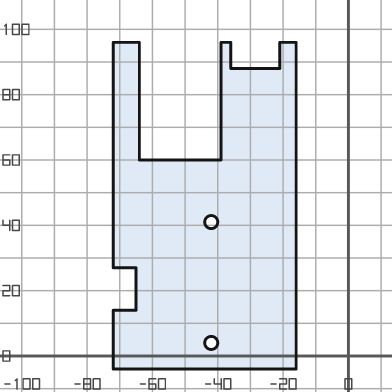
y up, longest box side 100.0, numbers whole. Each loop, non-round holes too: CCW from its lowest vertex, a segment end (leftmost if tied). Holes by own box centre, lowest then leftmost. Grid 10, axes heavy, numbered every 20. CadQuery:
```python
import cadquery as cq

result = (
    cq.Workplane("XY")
    .moveTo(-72.0, -4.0)
    .lineTo(-16.0, -4.0)
    .lineTo(-16.0, 96.0)
    .lineTo(-21.0, 96.0)
    .lineTo(-21.0, 88.0)
    .lineTo(-36.0, 88.0)
    .lineTo(-36.0, 96.0)
    .lineTo(-39.0, 96.0)
    .lineTo(-39.0, 60.0)
    .lineTo(-64.0, 60.0)
    .lineTo(-64.0, 96.0)
    .lineTo(-72.0, 96.0)
    .lineTo(-72.0, 27.0)
    .lineTo(-65.0, 27.0)
    .lineTo(-65.0, 14.0)
    .lineTo(-72.0, 14.0)
    .close()
    .moveTo(-42.0, 4.0)
    .circle(2.0)
    .moveTo(-42.0, 41.0)
    .circle(2.0)
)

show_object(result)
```